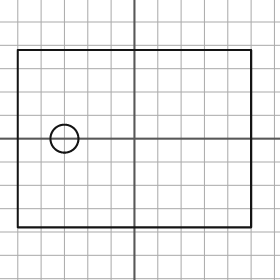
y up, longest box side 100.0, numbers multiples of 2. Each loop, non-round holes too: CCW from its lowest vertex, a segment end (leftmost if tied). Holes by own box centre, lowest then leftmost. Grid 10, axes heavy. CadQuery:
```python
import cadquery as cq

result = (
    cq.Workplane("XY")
    .moveTo(-50.0, -38.0)
    .lineTo(50.0, -38.0)
    .lineTo(50.0, 38.0)
    .lineTo(-50.0, 38.0)
    .close()
    .moveTo(-30.0, 0.0)
    .circle(6.0)
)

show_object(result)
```